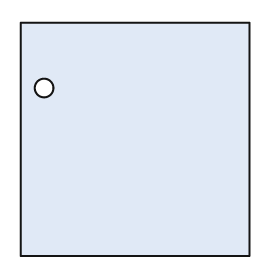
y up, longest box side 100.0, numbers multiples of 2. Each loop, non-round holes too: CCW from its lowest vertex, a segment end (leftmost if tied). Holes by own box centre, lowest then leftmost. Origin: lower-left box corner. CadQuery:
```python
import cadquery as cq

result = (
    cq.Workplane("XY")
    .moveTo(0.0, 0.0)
    .lineTo(98.0, 0.0)
    .lineTo(98.0, 100.0)
    .lineTo(0.0, 100.0)
    .close()
    .moveTo(10.0, 72.0)
    .circle(4.0)
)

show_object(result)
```